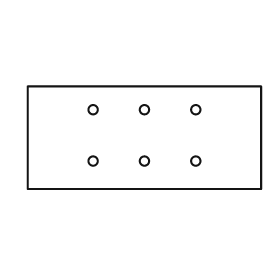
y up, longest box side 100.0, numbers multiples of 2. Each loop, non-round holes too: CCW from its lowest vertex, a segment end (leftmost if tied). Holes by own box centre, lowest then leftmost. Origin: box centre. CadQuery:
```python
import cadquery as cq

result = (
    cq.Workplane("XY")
    .moveTo(-50.0, -22.0)
    .lineTo(50.0, -22.0)
    .lineTo(50.0, 22.0)
    .lineTo(-50.0, 22.0)
    .close()
    .moveTo(-22.0, -10.0)
    .circle(2.0)
    .moveTo(0.0, -10.0)
    .circle(2.0)
    .moveTo(22.0, -10.0)
    .circle(2.0)
    .moveTo(-22.0, 12.0)
    .circle(2.0)
    .moveTo(0.0, 12.0)
    .circle(2.0)
    .moveTo(22.0, 12.0)
    .circle(2.0)
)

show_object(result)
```